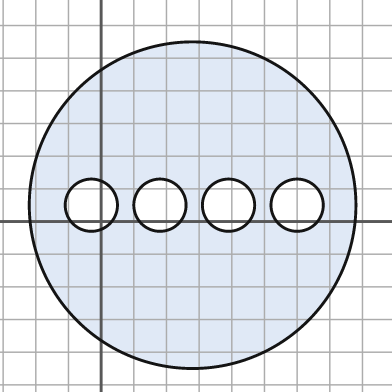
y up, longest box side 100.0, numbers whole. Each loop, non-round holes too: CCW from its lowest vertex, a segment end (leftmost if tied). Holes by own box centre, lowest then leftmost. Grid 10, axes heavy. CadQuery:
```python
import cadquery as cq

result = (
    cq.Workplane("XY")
    .moveTo(28.0, 5.0)
    .circle(50.0)
    .moveTo(-3.0, 5.0)
    .circle(8.0)
    .moveTo(18.0, 5.0)
    .circle(8.0)
    .moveTo(39.0, 5.0)
    .circle(8.0)
    .moveTo(60.0, 5.0)
    .circle(8.0)
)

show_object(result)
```